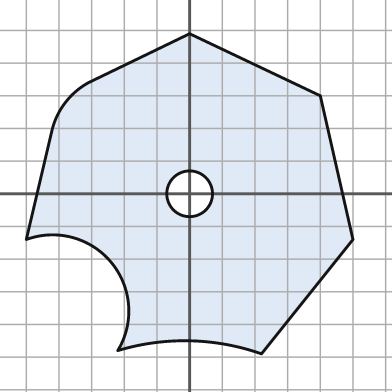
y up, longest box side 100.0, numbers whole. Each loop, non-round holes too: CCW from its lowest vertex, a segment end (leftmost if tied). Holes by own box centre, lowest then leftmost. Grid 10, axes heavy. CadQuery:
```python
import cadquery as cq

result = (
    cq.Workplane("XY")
    .moveTo(22.0, -49.0)
    .lineTo(50.0, -14.0)
    .lineTo(40.0, 30.0)
    .lineTo(0.0, 49.0)
    .lineTo(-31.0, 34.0)
    .threePointArc((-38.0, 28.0), (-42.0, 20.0))
    .lineTo(-50.0, -14.0)
    .threePointArc((-24.0, -21.0), (-22.0, -48.0))
    .threePointArc((0.0, -45.0), (22.0, -49.0))
    .close()
    .moveTo(0.0, 0.0)
    .circle(7.0)
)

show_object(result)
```